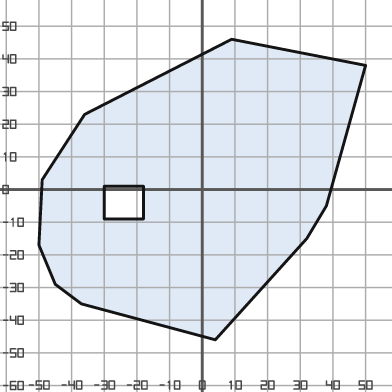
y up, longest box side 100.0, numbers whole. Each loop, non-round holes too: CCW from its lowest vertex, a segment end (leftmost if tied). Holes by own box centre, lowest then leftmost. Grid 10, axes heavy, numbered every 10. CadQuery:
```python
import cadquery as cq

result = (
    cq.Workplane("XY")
    .moveTo(4.0, -46.0)
    .lineTo(32.0, -15.0)
    .lineTo(38.0, -5.0)
    .lineTo(50.0, 38.0)
    .lineTo(9.0, 46.0)
    .lineTo(-36.0, 23.0)
    .lineTo(-49.0, 3.0)
    .lineTo(-50.0, -17.0)
    .lineTo(-45.0, -29.0)
    .lineTo(-37.0, -35.0)
    .close()
    .moveTo(-30.0, -9.0)
    .lineTo(-18.0, -9.0)
    .lineTo(-18.0, 1.0)
    .lineTo(-30.0, 1.0)
    .close()
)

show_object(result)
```